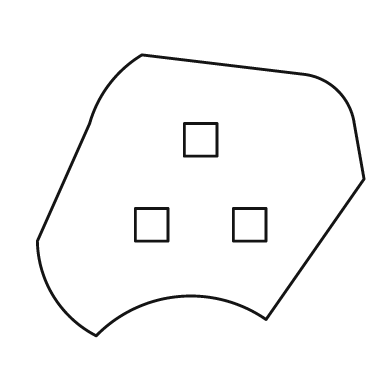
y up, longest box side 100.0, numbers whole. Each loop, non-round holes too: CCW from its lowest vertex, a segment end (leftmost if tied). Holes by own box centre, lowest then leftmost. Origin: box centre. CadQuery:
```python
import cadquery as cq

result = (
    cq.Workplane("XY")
    .moveTo(-32.0, -43.0)
    .threePointArc((-7.0, -31.0), (20.0, -38.0))
    .lineTo(50.0, 5.0)
    .lineTo(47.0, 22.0)
    .threePointArc((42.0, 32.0), (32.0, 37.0))
    .lineTo(-18.0, 43.0)
    .threePointArc((-28.0, 34.0), (-34.0, 22.0))
    .lineTo(-50.0, -14.0)
    .threePointArc((-45.0, -31.0), (-32.0, -43.0))
    .close()
    .moveTo(-20.0, -14.0)
    .lineTo(-10.0, -14.0)
    .lineTo(-10.0, -4.0)
    .lineTo(-20.0, -4.0)
    .close()
    .moveTo(10.0, -14.0)
    .lineTo(20.0, -14.0)
    .lineTo(20.0, -4.0)
    .lineTo(10.0, -4.0)
    .close()
    .moveTo(-5.0, 12.0)
    .lineTo(5.0, 12.0)
    .lineTo(5.0, 22.0)
    .lineTo(-5.0, 22.0)
    .close()
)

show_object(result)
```